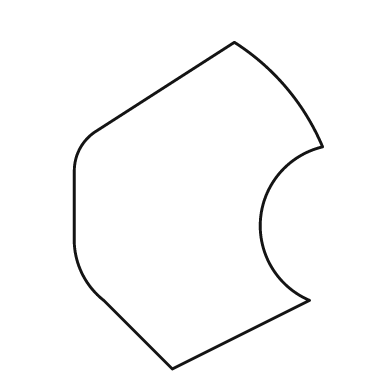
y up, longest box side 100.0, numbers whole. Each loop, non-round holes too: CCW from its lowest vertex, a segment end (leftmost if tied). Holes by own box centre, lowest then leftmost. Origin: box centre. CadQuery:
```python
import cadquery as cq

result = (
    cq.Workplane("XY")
    .moveTo(-8.0, -50.0)
    .lineTo(34.0, -29.0)
    .threePointArc((19.0, -4.0), (38.0, 18.0))
    .threePointArc((27.0, 36.0), (11.0, 50.0))
    .lineTo(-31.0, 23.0)
    .threePointArc((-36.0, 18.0), (-38.0, 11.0))
    .lineTo(-38.0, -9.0)
    .threePointArc((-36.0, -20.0), (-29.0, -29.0))
    .close()
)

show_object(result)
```